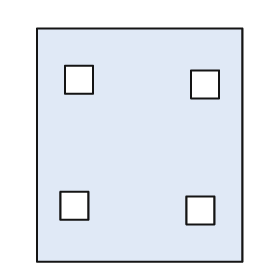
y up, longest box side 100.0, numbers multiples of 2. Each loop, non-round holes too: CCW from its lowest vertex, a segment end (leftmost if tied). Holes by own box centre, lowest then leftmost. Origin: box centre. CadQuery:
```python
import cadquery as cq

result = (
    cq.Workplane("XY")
    .moveTo(-44.0, -50.0)
    .lineTo(44.0, -50.0)
    .lineTo(44.0, 50.0)
    .lineTo(-44.0, 50.0)
    .close()
    .moveTo(20.0, -34.0)
    .lineTo(32.0, -34.0)
    .lineTo(32.0, -22.0)
    .lineTo(20.0, -22.0)
    .close()
    .moveTo(-34.0, -32.0)
    .lineTo(-22.0, -32.0)
    .lineTo(-22.0, -20.0)
    .lineTo(-34.0, -20.0)
    .close()
    .moveTo(22.0, 20.0)
    .lineTo(34.0, 20.0)
    .lineTo(34.0, 32.0)
    .lineTo(22.0, 32.0)
    .close()
    .moveTo(-32.0, 22.0)
    .lineTo(-20.0, 22.0)
    .lineTo(-20.0, 34.0)
    .lineTo(-32.0, 34.0)
    .close()
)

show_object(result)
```